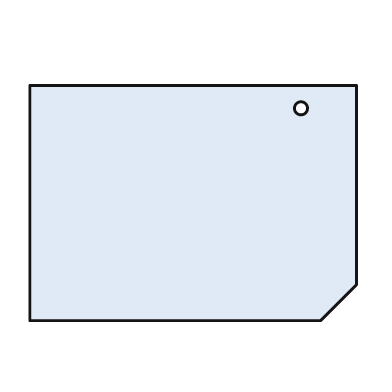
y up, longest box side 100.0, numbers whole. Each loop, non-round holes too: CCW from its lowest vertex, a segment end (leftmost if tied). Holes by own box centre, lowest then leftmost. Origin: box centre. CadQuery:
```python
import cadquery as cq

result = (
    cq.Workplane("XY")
    .moveTo(-50.0, -36.0)
    .lineTo(39.0, -36.0)
    .lineTo(50.0, -25.0)
    .lineTo(50.0, 36.0)
    .lineTo(-50.0, 36.0)
    .close()
    .moveTo(33.0, 29.0)
    .circle(2.0)
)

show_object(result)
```